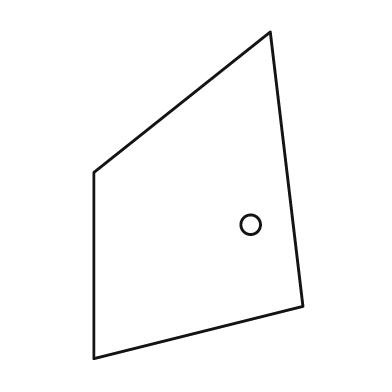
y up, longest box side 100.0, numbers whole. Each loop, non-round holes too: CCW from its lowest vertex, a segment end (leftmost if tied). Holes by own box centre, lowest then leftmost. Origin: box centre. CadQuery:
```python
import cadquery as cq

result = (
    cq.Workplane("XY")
    .moveTo(-32.0, -50.0)
    .lineTo(32.0, -34.0)
    .lineTo(22.0, 50.0)
    .lineTo(-32.0, 7.0)
    .close()
    .moveTo(16.0, -9.0)
    .circle(3.0)
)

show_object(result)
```